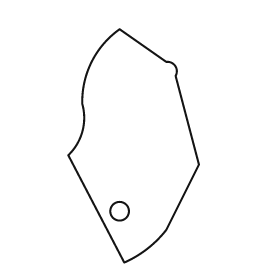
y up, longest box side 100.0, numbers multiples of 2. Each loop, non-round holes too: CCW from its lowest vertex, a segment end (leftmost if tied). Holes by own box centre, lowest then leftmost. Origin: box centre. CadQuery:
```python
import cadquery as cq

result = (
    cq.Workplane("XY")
    .moveTo(-4.0, -50.0)
    .threePointArc((6.0, -44.0), (14.0, -36.0))
    .lineTo(28.0, -8.0)
    .lineTo(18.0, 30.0)
    .threePointArc((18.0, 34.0), (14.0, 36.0))
    .lineTo(-6.0, 50.0)
    .threePointArc((-18.0, 36.0), (-22.0, 18.0))
    .threePointArc((-22.0, 6.0), (-28.0, -4.0))
    .close()
    .moveTo(-6.0, -28.0)
    .circle(4.0)
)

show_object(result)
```